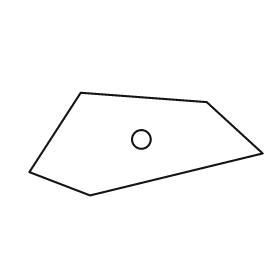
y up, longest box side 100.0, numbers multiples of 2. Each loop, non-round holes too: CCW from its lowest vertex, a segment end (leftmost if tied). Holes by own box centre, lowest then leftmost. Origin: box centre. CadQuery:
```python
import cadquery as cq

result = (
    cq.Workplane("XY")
    .moveTo(-24.0, -22.0)
    .lineTo(50.0, -4.0)
    .lineTo(26.0, 18.0)
    .lineTo(-28.0, 22.0)
    .lineTo(-50.0, -12.0)
    .close()
    .moveTo(-2.0, 2.0)
    .circle(4.0)
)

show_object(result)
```